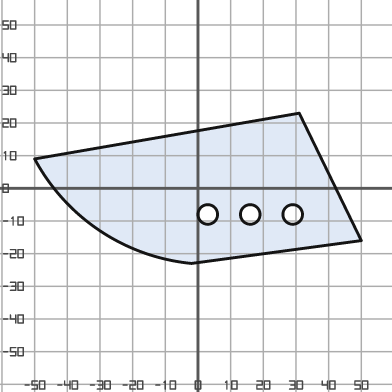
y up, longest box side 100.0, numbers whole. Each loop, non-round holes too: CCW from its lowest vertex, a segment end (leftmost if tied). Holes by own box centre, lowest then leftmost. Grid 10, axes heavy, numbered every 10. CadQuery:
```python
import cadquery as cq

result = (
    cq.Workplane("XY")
    .moveTo(-2.0, -23.0)
    .lineTo(50.0, -16.0)
    .lineTo(31.0, 23.0)
    .lineTo(-50.0, 9.0)
    .threePointArc((-30.0, -13.0), (-2.0, -23.0))
    .close()
    .moveTo(3.0, -8.0)
    .circle(3.0)
    .moveTo(16.0, -8.0)
    .circle(3.0)
    .moveTo(29.0, -8.0)
    .circle(3.0)
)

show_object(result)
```